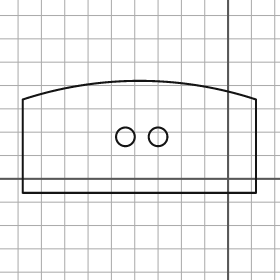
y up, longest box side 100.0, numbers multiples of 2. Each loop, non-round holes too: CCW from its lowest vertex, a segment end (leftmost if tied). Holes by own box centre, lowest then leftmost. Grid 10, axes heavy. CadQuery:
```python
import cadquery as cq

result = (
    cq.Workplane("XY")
    .moveTo(-88.0, -6.0)
    .lineTo(12.0, -6.0)
    .lineTo(12.0, 34.0)
    .threePointArc((-38.0, 42.0), (-88.0, 34.0))
    .close()
    .moveTo(-44.0, 18.0)
    .circle(4.0)
    .moveTo(-30.0, 18.0)
    .circle(4.0)
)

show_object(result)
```